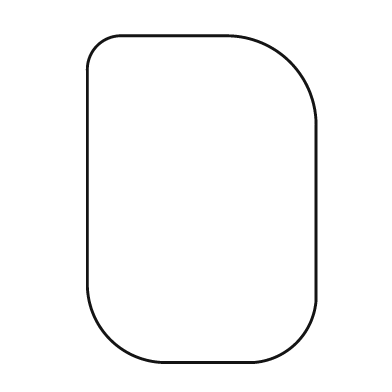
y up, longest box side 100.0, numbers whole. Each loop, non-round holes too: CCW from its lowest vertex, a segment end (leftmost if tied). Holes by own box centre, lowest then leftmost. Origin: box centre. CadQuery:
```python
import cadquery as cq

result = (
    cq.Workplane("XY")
    .moveTo(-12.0, -50.0)
    .lineTo(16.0, -50.0)
    .threePointArc((29.0, -44.0), (35.0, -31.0))
    .lineTo(35.0, 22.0)
    .threePointArc((27.0, 42.0), (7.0, 50.0))
    .lineTo(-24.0, 50.0)
    .threePointArc((-32.0, 47.0), (-35.0, 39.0))
    .lineTo(-35.0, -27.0)
    .threePointArc((-28.0, -43.0), (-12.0, -50.0))
    .close()
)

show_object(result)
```